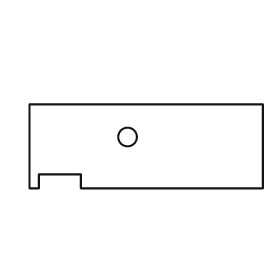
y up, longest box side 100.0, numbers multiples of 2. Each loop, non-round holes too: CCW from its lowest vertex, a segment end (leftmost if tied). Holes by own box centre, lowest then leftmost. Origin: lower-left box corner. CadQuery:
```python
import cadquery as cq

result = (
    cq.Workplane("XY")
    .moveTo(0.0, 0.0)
    .lineTo(4.0, 0.0)
    .lineTo(4.0, 6.0)
    .lineTo(22.0, 6.0)
    .lineTo(22.0, 0.0)
    .lineTo(100.0, 0.0)
    .lineTo(100.0, 36.0)
    .lineTo(0.0, 36.0)
    .close()
    .moveTo(42.0, 22.0)
    .circle(4.0)
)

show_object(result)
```